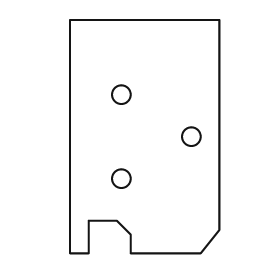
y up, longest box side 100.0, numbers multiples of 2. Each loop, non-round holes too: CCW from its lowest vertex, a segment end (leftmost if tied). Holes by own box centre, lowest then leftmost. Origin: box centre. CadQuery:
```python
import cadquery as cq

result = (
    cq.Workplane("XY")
    .moveTo(-32.0, -50.0)
    .lineTo(-24.0, -50.0)
    .lineTo(-24.0, -36.0)
    .lineTo(-12.0, -36.0)
    .lineTo(-6.0, -42.0)
    .lineTo(-6.0, -50.0)
    .lineTo(24.0, -50.0)
    .lineTo(32.0, -40.0)
    .lineTo(32.0, 50.0)
    .lineTo(-32.0, 50.0)
    .close()
    .moveTo(-10.0, -18.0)
    .circle(4.0)
    .moveTo(20.0, 0.0)
    .circle(4.0)
    .moveTo(-10.0, 18.0)
    .circle(4.0)
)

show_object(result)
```